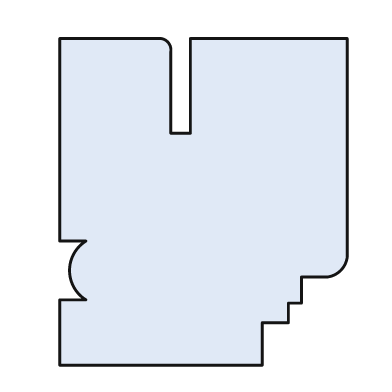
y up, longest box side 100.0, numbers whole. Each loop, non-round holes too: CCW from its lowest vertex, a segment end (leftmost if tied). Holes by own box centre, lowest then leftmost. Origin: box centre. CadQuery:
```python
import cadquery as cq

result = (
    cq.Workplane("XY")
    .moveTo(-44.0, -50.0)
    .lineTo(18.0, -50.0)
    .lineTo(18.0, -37.0)
    .lineTo(26.0, -37.0)
    .lineTo(26.0, -31.0)
    .lineTo(30.0, -31.0)
    .lineTo(30.0, -23.0)
    .lineTo(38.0, -23.0)
    .threePointArc((42.0, -21.0), (44.0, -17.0))
    .lineTo(44.0, 50.0)
    .lineTo(-4.0, 50.0)
    .lineTo(-4.0, 21.0)
    .lineTo(-10.0, 21.0)
    .lineTo(-10.0, 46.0)
    .threePointArc((-11.0, 49.0), (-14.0, 50.0))
    .lineTo(-44.0, 50.0)
    .lineTo(-44.0, -12.0)
    .lineTo(-36.0, -12.0)
    .threePointArc((-41.0, -21.0), (-36.0, -30.0))
    .lineTo(-44.0, -30.0)
    .close()
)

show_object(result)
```